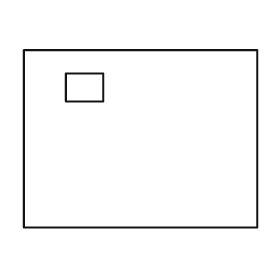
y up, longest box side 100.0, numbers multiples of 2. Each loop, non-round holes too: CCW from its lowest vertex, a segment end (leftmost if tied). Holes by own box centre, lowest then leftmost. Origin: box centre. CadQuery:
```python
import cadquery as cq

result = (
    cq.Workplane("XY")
    .moveTo(-50.0, -38.0)
    .lineTo(50.0, -38.0)
    .lineTo(50.0, 38.0)
    .lineTo(-50.0, 38.0)
    .close()
    .moveTo(-32.0, 16.0)
    .lineTo(-16.0, 16.0)
    .lineTo(-16.0, 28.0)
    .lineTo(-32.0, 28.0)
    .close()
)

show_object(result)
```